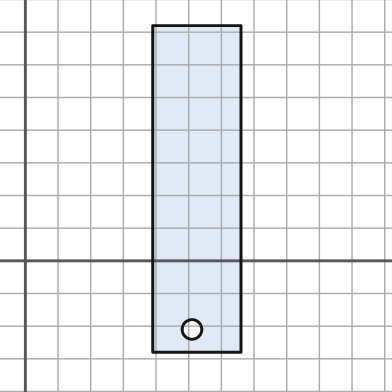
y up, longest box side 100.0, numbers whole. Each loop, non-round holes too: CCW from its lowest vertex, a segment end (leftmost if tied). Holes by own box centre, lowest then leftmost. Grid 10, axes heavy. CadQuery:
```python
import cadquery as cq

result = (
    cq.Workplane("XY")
    .moveTo(39.0, -28.0)
    .lineTo(66.0, -28.0)
    .lineTo(66.0, 72.0)
    .lineTo(39.0, 72.0)
    .close()
    .moveTo(51.0, -21.0)
    .circle(3.0)
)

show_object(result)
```